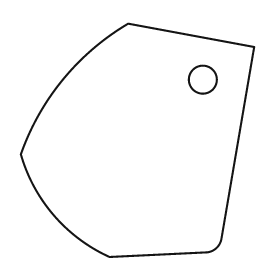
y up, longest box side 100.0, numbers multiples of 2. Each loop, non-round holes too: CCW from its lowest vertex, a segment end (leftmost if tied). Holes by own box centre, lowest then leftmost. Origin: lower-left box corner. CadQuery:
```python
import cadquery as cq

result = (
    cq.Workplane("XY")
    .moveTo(38.0, 0.0)
    .lineTo(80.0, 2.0)
    .threePointArc((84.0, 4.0), (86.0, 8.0))
    .lineTo(100.0, 90.0)
    .lineTo(46.0, 100.0)
    .threePointArc((18.0, 76.0), (0.0, 44.0))
    .threePointArc((14.0, 18.0), (38.0, 0.0))
    .close()
    .moveTo(78.0, 76.0)
    .circle(6.0)
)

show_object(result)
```